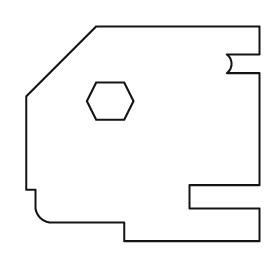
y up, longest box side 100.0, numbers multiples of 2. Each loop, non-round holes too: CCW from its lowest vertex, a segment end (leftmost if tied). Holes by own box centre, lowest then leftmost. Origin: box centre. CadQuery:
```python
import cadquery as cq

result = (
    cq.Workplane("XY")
    .moveTo(-8.0, -46.0)
    .lineTo(50.0, -46.0)
    .lineTo(50.0, -32.0)
    .lineTo(20.0, -32.0)
    .lineTo(20.0, -22.0)
    .lineTo(50.0, -22.0)
    .lineTo(50.0, 26.0)
    .lineTo(36.0, 26.0)
    .threePointArc((38.0, 30.0), (36.0, 34.0))
    .lineTo(50.0, 34.0)
    .lineTo(50.0, 46.0)
    .lineTo(-20.0, 46.0)
    .lineTo(-50.0, 16.0)
    .lineTo(-50.0, -24.0)
    .lineTo(-46.0, -24.0)
    .lineTo(-46.0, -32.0)
    .threePointArc((-44.0, -36.0), (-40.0, -38.0))
    .lineTo(-8.0, -38.0)
    .close()
    .moveTo(-20.0, 6.0)
    .lineTo(-8.0, 6.0)
    .lineTo(-4.0, 14.0)
    .lineTo(-8.0, 22.0)
    .lineTo(-20.0, 22.0)
    .lineTo(-24.0, 14.0)
    .close()
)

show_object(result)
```